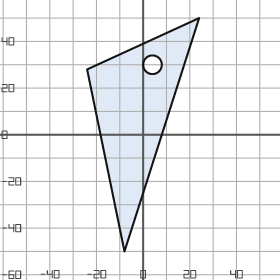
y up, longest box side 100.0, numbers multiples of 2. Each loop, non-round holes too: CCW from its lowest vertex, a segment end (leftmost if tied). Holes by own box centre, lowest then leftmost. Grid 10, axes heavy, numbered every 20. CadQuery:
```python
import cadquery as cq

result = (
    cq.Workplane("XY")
    .moveTo(-8.0, -50.0)
    .lineTo(24.0, 50.0)
    .lineTo(-24.0, 28.0)
    .close()
    .moveTo(4.0, 30.0)
    .circle(4.0)
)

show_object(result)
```